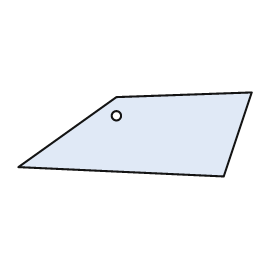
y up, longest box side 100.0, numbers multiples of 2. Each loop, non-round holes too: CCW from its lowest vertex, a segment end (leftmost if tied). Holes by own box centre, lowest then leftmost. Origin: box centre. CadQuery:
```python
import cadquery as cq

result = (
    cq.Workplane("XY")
    .moveTo(38.0, -18.0)
    .lineTo(50.0, 18.0)
    .lineTo(-8.0, 16.0)
    .lineTo(-50.0, -14.0)
    .close()
    .moveTo(-8.0, 8.0)
    .circle(2.0)
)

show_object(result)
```